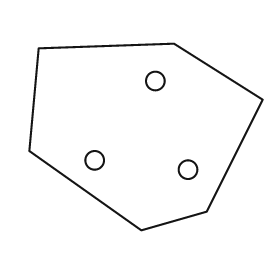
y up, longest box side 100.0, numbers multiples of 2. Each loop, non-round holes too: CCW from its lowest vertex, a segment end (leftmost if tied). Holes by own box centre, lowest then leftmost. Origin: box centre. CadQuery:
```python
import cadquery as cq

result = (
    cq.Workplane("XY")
    .moveTo(-2.0, -40.0)
    .lineTo(26.0, -32.0)
    .lineTo(50.0, 16.0)
    .lineTo(12.0, 40.0)
    .lineTo(-46.0, 38.0)
    .lineTo(-50.0, -6.0)
    .close()
    .moveTo(18.0, -14.0)
    .circle(4.0)
    .moveTo(-22.0, -10.0)
    .circle(4.0)
    .moveTo(4.0, 24.0)
    .circle(4.0)
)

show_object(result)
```